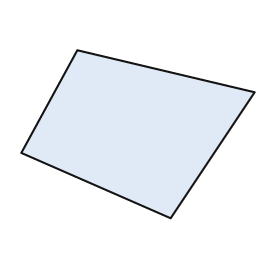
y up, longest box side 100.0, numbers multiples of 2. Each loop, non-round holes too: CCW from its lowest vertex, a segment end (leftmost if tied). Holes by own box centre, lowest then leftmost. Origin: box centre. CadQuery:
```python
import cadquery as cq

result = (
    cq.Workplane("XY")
    .moveTo(14.0, -36.0)
    .lineTo(50.0, 18.0)
    .lineTo(-26.0, 36.0)
    .lineTo(-50.0, -8.0)
    .close()
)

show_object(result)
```